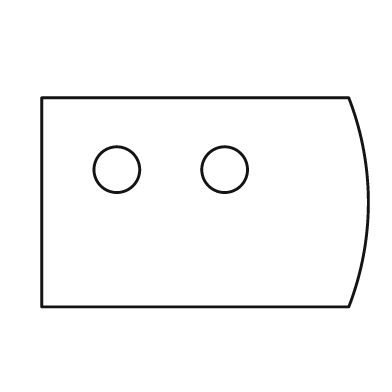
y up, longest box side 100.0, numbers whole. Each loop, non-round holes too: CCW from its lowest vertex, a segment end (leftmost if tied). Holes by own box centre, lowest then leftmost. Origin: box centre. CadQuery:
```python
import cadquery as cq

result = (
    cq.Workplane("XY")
    .moveTo(-50.0, -32.0)
    .lineTo(44.0, -32.0)
    .threePointArc((50.0, 0.0), (44.0, 32.0))
    .lineTo(-50.0, 32.0)
    .close()
    .moveTo(-27.0, 10.0)
    .circle(7.0)
    .moveTo(6.0, 10.0)
    .circle(7.0)
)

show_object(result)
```